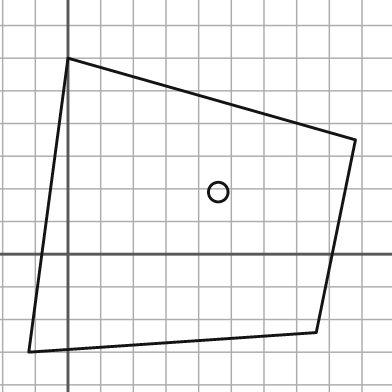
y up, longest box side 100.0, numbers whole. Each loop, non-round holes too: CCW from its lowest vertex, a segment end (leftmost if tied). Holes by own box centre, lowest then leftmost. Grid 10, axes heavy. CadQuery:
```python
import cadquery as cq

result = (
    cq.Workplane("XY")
    .moveTo(-12.0, -30.0)
    .lineTo(76.0, -24.0)
    .lineTo(88.0, 35.0)
    .lineTo(0.0, 60.0)
    .close()
    .moveTo(46.0, 19.0)
    .circle(3.0)
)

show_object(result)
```